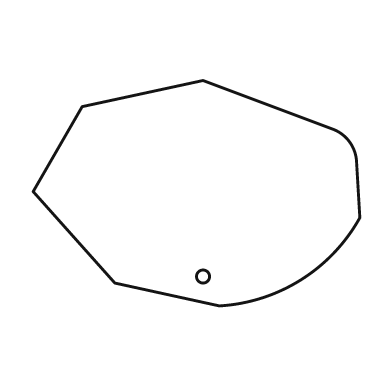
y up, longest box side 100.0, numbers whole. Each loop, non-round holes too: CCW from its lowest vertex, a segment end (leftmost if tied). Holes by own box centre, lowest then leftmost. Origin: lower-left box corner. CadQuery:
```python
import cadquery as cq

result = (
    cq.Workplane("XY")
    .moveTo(57.0, 0.0)
    .threePointArc((82.0, 8.0), (100.0, 27.0))
    .lineTo(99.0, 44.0)
    .threePointArc((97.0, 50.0), (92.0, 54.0))
    .lineTo(52.0, 69.0)
    .lineTo(15.0, 61.0)
    .lineTo(0.0, 35.0)
    .lineTo(25.0, 7.0)
    .close()
    .moveTo(52.0, 9.0)
    .circle(2.0)
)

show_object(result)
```